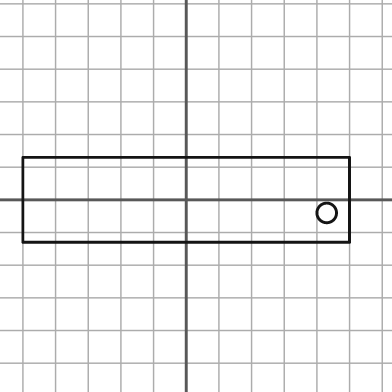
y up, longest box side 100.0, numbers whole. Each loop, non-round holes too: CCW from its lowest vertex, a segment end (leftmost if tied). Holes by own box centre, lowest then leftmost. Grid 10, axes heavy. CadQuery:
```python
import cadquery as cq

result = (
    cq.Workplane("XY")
    .moveTo(-50.0, -13.0)
    .lineTo(50.0, -13.0)
    .lineTo(50.0, 13.0)
    .lineTo(-50.0, 13.0)
    .close()
    .moveTo(43.0, -4.0)
    .circle(3.0)
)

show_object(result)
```